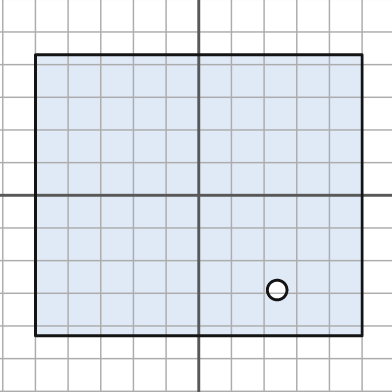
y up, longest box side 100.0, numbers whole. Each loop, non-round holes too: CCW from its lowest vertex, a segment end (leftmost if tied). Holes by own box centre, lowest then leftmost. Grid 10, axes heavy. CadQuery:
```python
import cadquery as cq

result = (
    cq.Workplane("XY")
    .moveTo(-50.0, -43.0)
    .lineTo(50.0, -43.0)
    .lineTo(50.0, 43.0)
    .lineTo(-50.0, 43.0)
    .close()
    .moveTo(24.0, -29.0)
    .circle(3.0)
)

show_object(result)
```